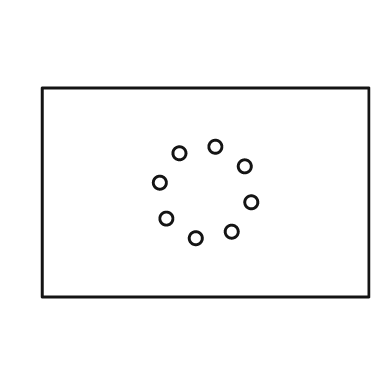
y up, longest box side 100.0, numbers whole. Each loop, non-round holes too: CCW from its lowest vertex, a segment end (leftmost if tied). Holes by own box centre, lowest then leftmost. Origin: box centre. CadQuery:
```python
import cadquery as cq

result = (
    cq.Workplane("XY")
    .moveTo(-50.0, -32.0)
    .lineTo(50.0, -32.0)
    .lineTo(50.0, 32.0)
    .lineTo(-50.0, 32.0)
    .close()
    .moveTo(-3.0, -14.0)
    .circle(2.0)
    .moveTo(8.0, -12.0)
    .circle(2.0)
    .moveTo(-12.0, -8.0)
    .circle(2.0)
    .moveTo(14.0, -3.0)
    .circle(2.0)
    .moveTo(-14.0, 3.0)
    .circle(2.0)
    .moveTo(12.0, 8.0)
    .circle(2.0)
    .moveTo(-8.0, 12.0)
    .circle(2.0)
    .moveTo(3.0, 14.0)
    .circle(2.0)
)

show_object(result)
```